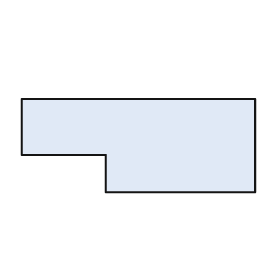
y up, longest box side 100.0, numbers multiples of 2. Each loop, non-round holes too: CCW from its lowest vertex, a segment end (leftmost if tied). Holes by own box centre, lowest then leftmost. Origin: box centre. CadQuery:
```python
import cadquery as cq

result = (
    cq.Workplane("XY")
    .moveTo(-14.0, -20.0)
    .lineTo(50.0, -20.0)
    .lineTo(50.0, 20.0)
    .lineTo(-50.0, 20.0)
    .lineTo(-50.0, -4.0)
    .lineTo(-14.0, -4.0)
    .close()
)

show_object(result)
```